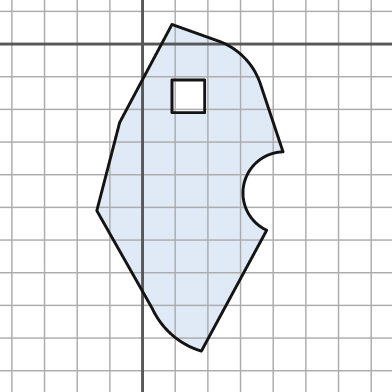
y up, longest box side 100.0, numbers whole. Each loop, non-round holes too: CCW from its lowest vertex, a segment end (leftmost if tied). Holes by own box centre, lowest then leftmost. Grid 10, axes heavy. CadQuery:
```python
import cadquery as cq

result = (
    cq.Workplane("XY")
    .moveTo(18.0, -94.0)
    .lineTo(38.0, -57.0)
    .threePointArc((31.0, -43.0), (43.0, -33.0))
    .lineTo(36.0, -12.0)
    .threePointArc((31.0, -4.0), (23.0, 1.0))
    .lineTo(9.0, 6.0)
    .lineTo(-7.0, -24.0)
    .lineTo(-14.0, -51.0)
    .lineTo(3.0, -81.0)
    .threePointArc((9.0, -89.0), (18.0, -94.0))
    .close()
    .moveTo(9.0, -21.0)
    .lineTo(19.0, -21.0)
    .lineTo(19.0, -11.0)
    .lineTo(9.0, -11.0)
    .close()
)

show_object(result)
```